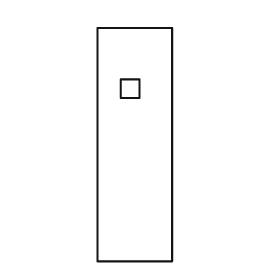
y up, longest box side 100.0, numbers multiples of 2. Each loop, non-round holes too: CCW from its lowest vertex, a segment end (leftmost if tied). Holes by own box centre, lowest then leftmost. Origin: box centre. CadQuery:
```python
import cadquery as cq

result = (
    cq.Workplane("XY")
    .moveTo(-16.0, -50.0)
    .lineTo(16.0, -50.0)
    .lineTo(16.0, 50.0)
    .lineTo(-16.0, 50.0)
    .close()
    .moveTo(-6.0, 20.0)
    .lineTo(2.0, 20.0)
    .lineTo(2.0, 28.0)
    .lineTo(-6.0, 28.0)
    .close()
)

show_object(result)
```